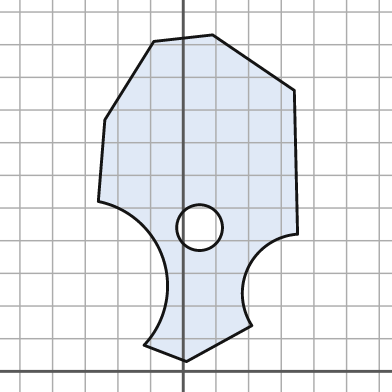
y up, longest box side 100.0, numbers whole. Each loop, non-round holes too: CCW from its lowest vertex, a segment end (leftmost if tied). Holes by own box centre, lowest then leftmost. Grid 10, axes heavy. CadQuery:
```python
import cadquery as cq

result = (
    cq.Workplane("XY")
    .moveTo(1.0, 3.0)
    .lineTo(21.0, 14.0)
    .threePointArc((20.0, 32.0), (35.0, 42.0))
    .lineTo(34.0, 86.0)
    .lineTo(9.0, 103.0)
    .lineTo(-9.0, 101.0)
    .lineTo(-24.0, 77.0)
    .lineTo(-26.0, 52.0)
    .threePointArc((-6.0, 34.0), (-12.0, 8.0))
    .close()
    .moveTo(5.0, 44.0)
    .circle(7.0)
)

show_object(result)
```